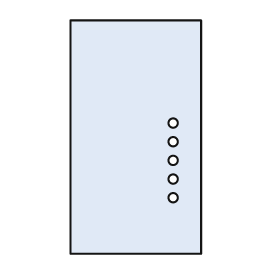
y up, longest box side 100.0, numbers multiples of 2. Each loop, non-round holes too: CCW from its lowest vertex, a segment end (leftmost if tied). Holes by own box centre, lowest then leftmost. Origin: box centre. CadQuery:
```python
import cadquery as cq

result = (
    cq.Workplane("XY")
    .moveTo(-28.0, -50.0)
    .lineTo(28.0, -50.0)
    .lineTo(28.0, 50.0)
    .lineTo(-28.0, 50.0)
    .close()
    .moveTo(16.0, -26.0)
    .circle(2.0)
    .moveTo(16.0, -18.0)
    .circle(2.0)
    .moveTo(16.0, -10.0)
    .circle(2.0)
    .moveTo(16.0, -2.0)
    .circle(2.0)
    .moveTo(16.0, 6.0)
    .circle(2.0)
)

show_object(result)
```